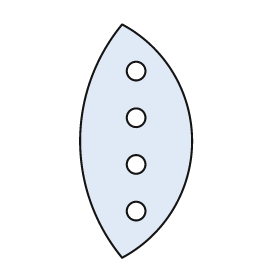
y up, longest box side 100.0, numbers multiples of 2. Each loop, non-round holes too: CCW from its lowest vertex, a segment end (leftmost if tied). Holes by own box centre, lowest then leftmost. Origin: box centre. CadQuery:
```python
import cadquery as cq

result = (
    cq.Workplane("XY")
    .moveTo(-6.0, -50.0)
    .threePointArc((24.0, 0.0), (-6.0, 50.0))
    .threePointArc((-24.0, 0.0), (-6.0, -50.0))
    .close()
    .moveTo(0.0, -30.0)
    .circle(4.0)
    .moveTo(0.0, -10.0)
    .circle(4.0)
    .moveTo(0.0, 10.0)
    .circle(4.0)
    .moveTo(0.0, 30.0)
    .circle(4.0)
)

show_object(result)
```